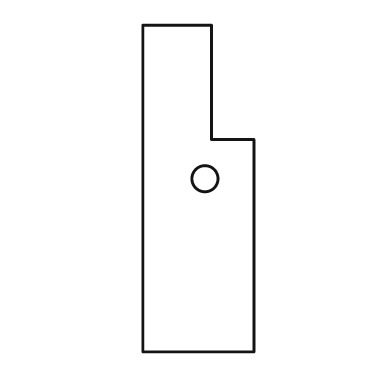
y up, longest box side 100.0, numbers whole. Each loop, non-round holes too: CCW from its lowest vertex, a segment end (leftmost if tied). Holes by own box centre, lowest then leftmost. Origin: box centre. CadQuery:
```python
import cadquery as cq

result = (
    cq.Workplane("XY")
    .moveTo(-17.0, -50.0)
    .lineTo(17.0, -50.0)
    .lineTo(17.0, 15.0)
    .lineTo(4.0, 15.0)
    .lineTo(4.0, 50.0)
    .lineTo(-17.0, 50.0)
    .close()
    .moveTo(2.0, 3.0)
    .circle(4.0)
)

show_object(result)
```